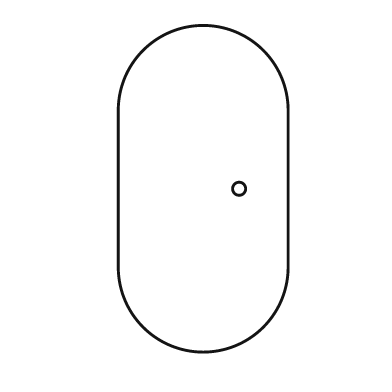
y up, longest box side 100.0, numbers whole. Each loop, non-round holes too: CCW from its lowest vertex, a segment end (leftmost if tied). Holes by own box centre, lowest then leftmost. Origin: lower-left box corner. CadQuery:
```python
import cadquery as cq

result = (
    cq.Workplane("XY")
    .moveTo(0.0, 26.0)
    .threePointArc((26.0, 0.0), (52.0, 26.0))
    .lineTo(52.0, 74.0)
    .threePointArc((26.0, 100.0), (0.0, 74.0))
    .close()
    .moveTo(37.0, 50.0)
    .circle(2.0)
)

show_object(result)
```